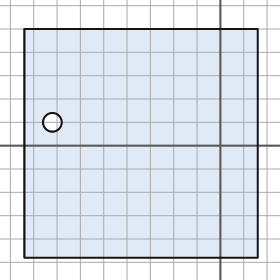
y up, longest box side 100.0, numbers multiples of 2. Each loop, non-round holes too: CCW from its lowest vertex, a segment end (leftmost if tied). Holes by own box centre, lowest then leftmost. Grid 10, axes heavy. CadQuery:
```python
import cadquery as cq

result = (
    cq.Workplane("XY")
    .moveTo(-84.0, -48.0)
    .lineTo(16.0, -48.0)
    .lineTo(16.0, 50.0)
    .lineTo(-84.0, 50.0)
    .close()
    .moveTo(-72.0, 10.0)
    .circle(4.0)
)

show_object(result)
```